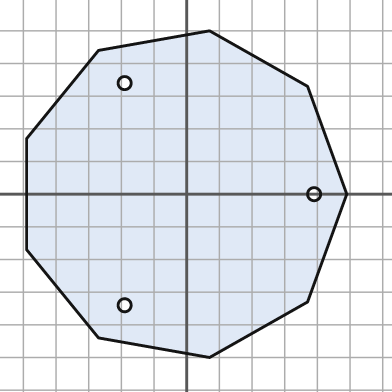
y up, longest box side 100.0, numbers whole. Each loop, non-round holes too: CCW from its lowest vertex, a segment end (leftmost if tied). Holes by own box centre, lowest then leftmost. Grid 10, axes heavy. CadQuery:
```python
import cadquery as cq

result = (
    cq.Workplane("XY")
    .moveTo(7.0, -50.0)
    .lineTo(37.0, -33.0)
    .lineTo(49.0, 0.0)
    .lineTo(37.0, 33.0)
    .lineTo(7.0, 50.0)
    .lineTo(-27.0, 44.0)
    .lineTo(-49.0, 17.0)
    .lineTo(-49.0, -17.0)
    .lineTo(-27.0, -44.0)
    .close()
    .moveTo(-19.0, -34.0)
    .circle(2.0)
    .moveTo(39.0, 0.0)
    .circle(2.0)
    .moveTo(-19.0, 34.0)
    .circle(2.0)
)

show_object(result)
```